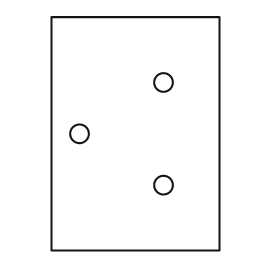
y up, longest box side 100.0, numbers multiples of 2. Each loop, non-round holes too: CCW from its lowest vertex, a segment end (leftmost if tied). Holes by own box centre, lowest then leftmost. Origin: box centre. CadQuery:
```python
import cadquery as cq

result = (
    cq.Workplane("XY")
    .moveTo(-36.0, -50.0)
    .lineTo(36.0, -50.0)
    .lineTo(36.0, 50.0)
    .lineTo(-36.0, 50.0)
    .close()
    .moveTo(12.0, -22.0)
    .circle(4.0)
    .moveTo(-24.0, 0.0)
    .circle(4.0)
    .moveTo(12.0, 22.0)
    .circle(4.0)
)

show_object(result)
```